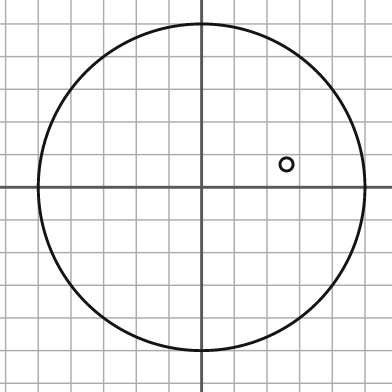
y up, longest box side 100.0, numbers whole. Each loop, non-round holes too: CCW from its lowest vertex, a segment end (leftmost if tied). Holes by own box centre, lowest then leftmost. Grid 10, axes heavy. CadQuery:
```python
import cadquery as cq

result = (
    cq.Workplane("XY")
    .moveTo(0.0, 0.0)
    .circle(50.0)
    .moveTo(26.0, 7.0)
    .circle(2.0)
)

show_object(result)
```